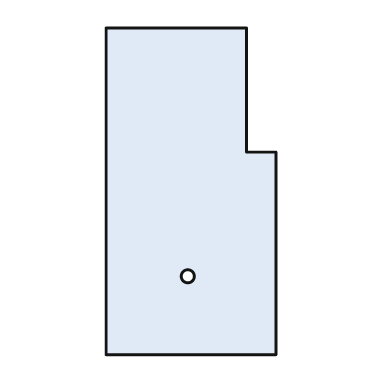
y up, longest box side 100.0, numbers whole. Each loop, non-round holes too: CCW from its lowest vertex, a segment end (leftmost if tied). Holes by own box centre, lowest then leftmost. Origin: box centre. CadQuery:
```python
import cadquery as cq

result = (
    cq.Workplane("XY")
    .moveTo(-26.0, -50.0)
    .lineTo(26.0, -50.0)
    .lineTo(26.0, 12.0)
    .lineTo(17.0, 12.0)
    .lineTo(17.0, 50.0)
    .lineTo(-26.0, 50.0)
    .close()
    .moveTo(-1.0, -26.0)
    .circle(2.0)
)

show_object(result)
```